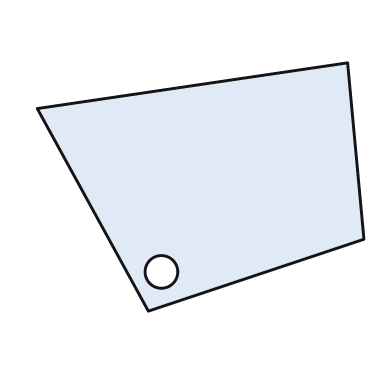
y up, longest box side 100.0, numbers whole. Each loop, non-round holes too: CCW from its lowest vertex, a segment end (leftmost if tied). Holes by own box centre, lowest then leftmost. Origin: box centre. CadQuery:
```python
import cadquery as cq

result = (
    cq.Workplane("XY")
    .moveTo(-16.0, -38.0)
    .lineTo(50.0, -16.0)
    .lineTo(45.0, 38.0)
    .lineTo(-50.0, 24.0)
    .close()
    .moveTo(-12.0, -26.0)
    .circle(5.0)
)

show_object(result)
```